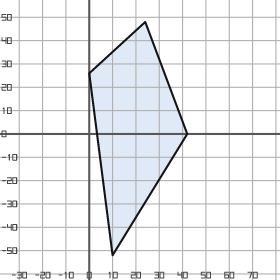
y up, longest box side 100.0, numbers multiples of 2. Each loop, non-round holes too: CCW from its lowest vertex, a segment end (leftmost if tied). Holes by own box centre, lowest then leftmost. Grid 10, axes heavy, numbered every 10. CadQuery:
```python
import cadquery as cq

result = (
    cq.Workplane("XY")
    .moveTo(10.0, -52.0)
    .lineTo(42.0, 0.0)
    .lineTo(24.0, 48.0)
    .lineTo(0.0, 26.0)
    .close()
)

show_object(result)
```